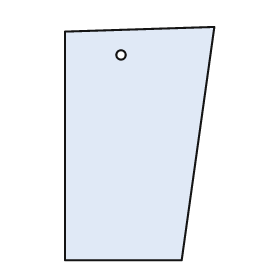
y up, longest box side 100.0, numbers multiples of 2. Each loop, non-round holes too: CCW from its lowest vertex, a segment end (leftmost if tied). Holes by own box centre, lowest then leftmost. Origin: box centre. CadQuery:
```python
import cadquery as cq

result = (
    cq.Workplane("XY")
    .moveTo(-32.0, -50.0)
    .lineTo(18.0, -50.0)
    .lineTo(32.0, 50.0)
    .lineTo(-32.0, 48.0)
    .close()
    .moveTo(-8.0, 38.0)
    .circle(2.0)
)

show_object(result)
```